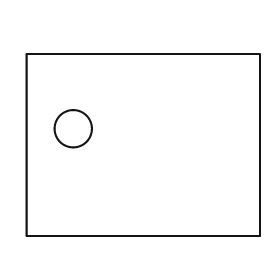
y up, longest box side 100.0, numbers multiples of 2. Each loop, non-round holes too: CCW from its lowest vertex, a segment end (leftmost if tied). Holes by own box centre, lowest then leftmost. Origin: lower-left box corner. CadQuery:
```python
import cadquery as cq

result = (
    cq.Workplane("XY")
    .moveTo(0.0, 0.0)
    .lineTo(100.0, 0.0)
    .lineTo(100.0, 78.0)
    .lineTo(0.0, 78.0)
    .close()
    .moveTo(20.0, 46.0)
    .circle(8.0)
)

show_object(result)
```